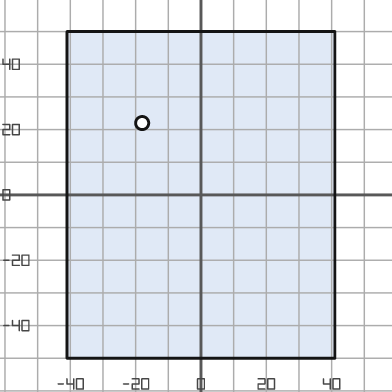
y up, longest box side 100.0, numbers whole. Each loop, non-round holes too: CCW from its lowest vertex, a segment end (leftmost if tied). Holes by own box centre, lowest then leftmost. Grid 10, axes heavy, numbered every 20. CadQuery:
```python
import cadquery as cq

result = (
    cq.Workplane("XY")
    .moveTo(-41.0, -50.0)
    .lineTo(41.0, -50.0)
    .lineTo(41.0, 50.0)
    .lineTo(-41.0, 50.0)
    .close()
    .moveTo(-18.0, 22.0)
    .circle(2.0)
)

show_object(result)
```